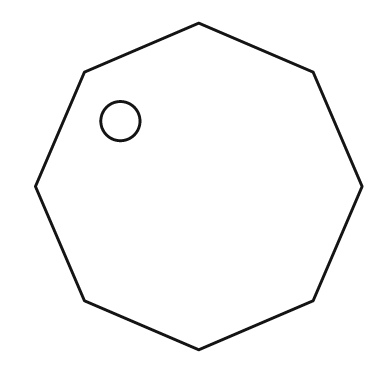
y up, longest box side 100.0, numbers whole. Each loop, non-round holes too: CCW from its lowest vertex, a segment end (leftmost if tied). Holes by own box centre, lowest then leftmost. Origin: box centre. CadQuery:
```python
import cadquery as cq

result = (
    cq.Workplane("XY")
    .moveTo(0.0, -50.0)
    .lineTo(35.0, -35.0)
    .lineTo(50.0, 0.0)
    .lineTo(35.0, 35.0)
    .lineTo(0.0, 50.0)
    .lineTo(-35.0, 35.0)
    .lineTo(-50.0, 0.0)
    .lineTo(-35.0, -35.0)
    .close()
    .moveTo(-24.0, 20.0)
    .circle(6.0)
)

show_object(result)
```